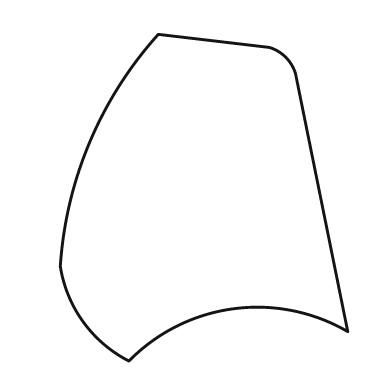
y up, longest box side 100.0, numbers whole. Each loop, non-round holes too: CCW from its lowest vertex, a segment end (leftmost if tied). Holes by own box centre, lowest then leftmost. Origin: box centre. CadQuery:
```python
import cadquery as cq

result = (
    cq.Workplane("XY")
    .moveTo(-23.0, -50.0)
    .threePointArc((9.0, -34.0), (44.0, -41.0))
    .lineTo(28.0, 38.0)
    .threePointArc((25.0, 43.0), (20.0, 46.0))
    .lineTo(-14.0, 50.0)
    .threePointArc((-35.0, 17.0), (-44.0, -21.0))
    .threePointArc((-37.0, -38.0), (-23.0, -50.0))
    .close()
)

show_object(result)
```